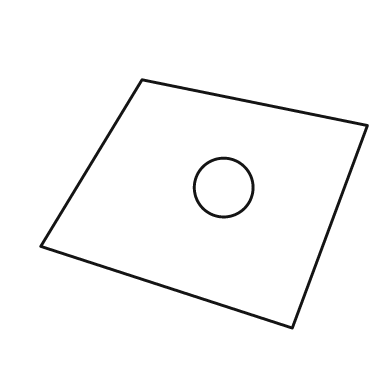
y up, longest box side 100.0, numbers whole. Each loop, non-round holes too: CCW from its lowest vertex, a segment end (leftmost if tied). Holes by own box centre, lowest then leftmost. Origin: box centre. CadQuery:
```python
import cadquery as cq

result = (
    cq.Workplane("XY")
    .moveTo(27.0, -38.0)
    .lineTo(50.0, 24.0)
    .lineTo(-19.0, 38.0)
    .lineTo(-50.0, -13.0)
    .close()
    .moveTo(6.0, 5.0)
    .circle(9.0)
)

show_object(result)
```